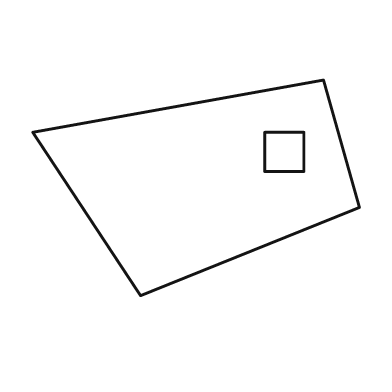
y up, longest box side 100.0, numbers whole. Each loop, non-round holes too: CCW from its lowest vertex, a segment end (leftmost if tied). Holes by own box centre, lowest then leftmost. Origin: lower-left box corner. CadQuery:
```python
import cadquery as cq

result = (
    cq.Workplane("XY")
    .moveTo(33.0, 0.0)
    .lineTo(100.0, 27.0)
    .lineTo(89.0, 66.0)
    .lineTo(0.0, 50.0)
    .close()
    .moveTo(71.0, 38.0)
    .lineTo(83.0, 38.0)
    .lineTo(83.0, 50.0)
    .lineTo(71.0, 50.0)
    .close()
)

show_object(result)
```